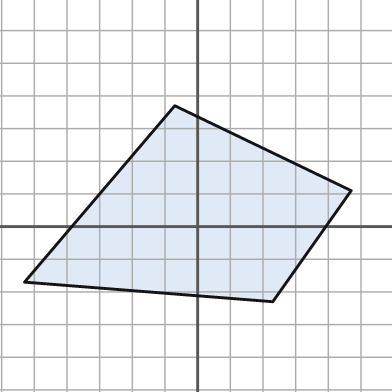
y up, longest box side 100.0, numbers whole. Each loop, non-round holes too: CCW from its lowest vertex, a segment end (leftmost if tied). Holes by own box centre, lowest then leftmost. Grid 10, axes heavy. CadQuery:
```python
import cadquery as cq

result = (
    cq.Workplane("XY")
    .moveTo(23.0, -23.0)
    .lineTo(47.0, 11.0)
    .lineTo(-7.0, 37.0)
    .lineTo(-53.0, -17.0)
    .close()
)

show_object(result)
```